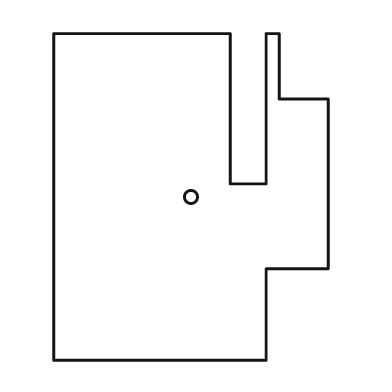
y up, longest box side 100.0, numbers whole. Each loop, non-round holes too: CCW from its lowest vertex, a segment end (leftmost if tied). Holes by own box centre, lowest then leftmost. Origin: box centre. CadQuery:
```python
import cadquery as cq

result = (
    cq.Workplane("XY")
    .moveTo(-42.0, -50.0)
    .lineTo(23.0, -50.0)
    .lineTo(23.0, -22.0)
    .lineTo(42.0, -22.0)
    .lineTo(42.0, 30.0)
    .lineTo(27.0, 30.0)
    .lineTo(27.0, 50.0)
    .lineTo(23.0, 50.0)
    .lineTo(23.0, 4.0)
    .lineTo(12.0, 4.0)
    .lineTo(12.0, 50.0)
    .lineTo(-42.0, 50.0)
    .close()
    .moveTo(0.0, 0.0)
    .circle(2.0)
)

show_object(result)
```